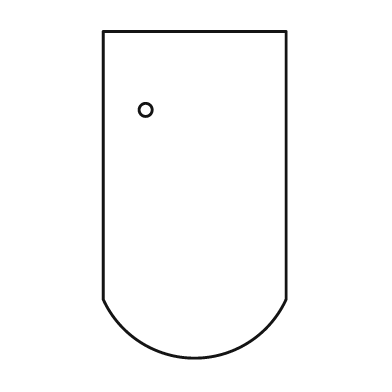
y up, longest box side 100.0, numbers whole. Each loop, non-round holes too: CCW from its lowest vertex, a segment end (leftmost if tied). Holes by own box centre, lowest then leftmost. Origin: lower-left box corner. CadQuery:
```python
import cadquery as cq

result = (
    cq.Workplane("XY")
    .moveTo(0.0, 18.0)
    .threePointArc((28.0, 0.0), (56.0, 18.0))
    .lineTo(56.0, 100.0)
    .lineTo(0.0, 100.0)
    .close()
    .moveTo(13.0, 76.0)
    .circle(2.0)
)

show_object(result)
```